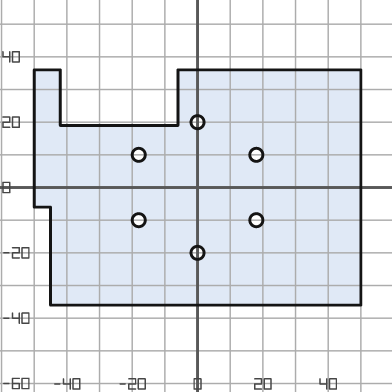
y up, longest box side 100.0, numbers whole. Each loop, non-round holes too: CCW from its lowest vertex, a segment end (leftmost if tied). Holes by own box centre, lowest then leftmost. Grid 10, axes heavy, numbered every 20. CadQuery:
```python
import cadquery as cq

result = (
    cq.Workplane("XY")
    .moveTo(-45.0, -36.0)
    .lineTo(50.0, -36.0)
    .lineTo(50.0, 36.0)
    .lineTo(-6.0, 36.0)
    .lineTo(-6.0, 19.0)
    .lineTo(-42.0, 19.0)
    .lineTo(-42.0, 36.0)
    .lineTo(-50.0, 36.0)
    .lineTo(-50.0, -6.0)
    .lineTo(-45.0, -6.0)
    .close()
    .moveTo(0.0, -20.0)
    .circle(2.0)
    .moveTo(-18.0, -10.0)
    .circle(2.0)
    .moveTo(18.0, -10.0)
    .circle(2.0)
    .moveTo(-18.0, 10.0)
    .circle(2.0)
    .moveTo(18.0, 10.0)
    .circle(2.0)
    .moveTo(0.0, 20.0)
    .circle(2.0)
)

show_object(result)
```